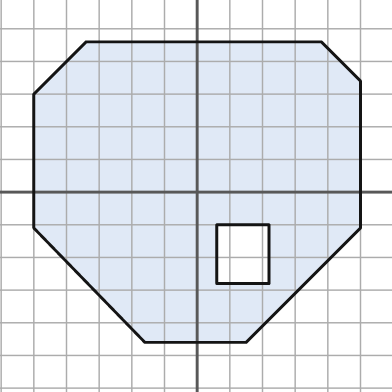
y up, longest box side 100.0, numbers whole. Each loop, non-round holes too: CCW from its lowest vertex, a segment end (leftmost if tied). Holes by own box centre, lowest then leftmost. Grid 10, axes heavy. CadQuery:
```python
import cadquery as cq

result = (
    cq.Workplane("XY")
    .moveTo(-16.0, -46.0)
    .lineTo(15.0, -46.0)
    .lineTo(50.0, -11.0)
    .lineTo(50.0, 34.0)
    .lineTo(38.0, 46.0)
    .lineTo(-34.0, 46.0)
    .lineTo(-50.0, 30.0)
    .lineTo(-50.0, -11.0)
    .close()
    .moveTo(6.0, -28.0)
    .lineTo(22.0, -28.0)
    .lineTo(22.0, -10.0)
    .lineTo(6.0, -10.0)
    .close()
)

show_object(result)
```